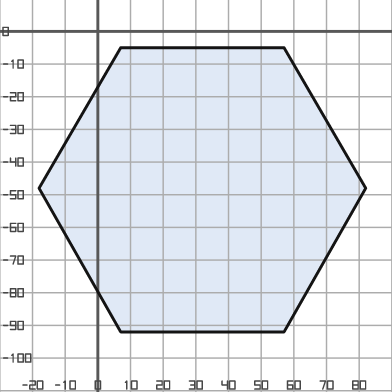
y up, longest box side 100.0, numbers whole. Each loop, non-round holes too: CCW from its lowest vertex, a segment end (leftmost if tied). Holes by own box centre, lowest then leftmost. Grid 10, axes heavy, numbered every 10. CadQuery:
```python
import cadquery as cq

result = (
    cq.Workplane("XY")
    .moveTo(7.0, -92.0)
    .lineTo(57.0, -92.0)
    .lineTo(82.0, -48.0)
    .lineTo(57.0, -5.0)
    .lineTo(7.0, -5.0)
    .lineTo(-18.0, -48.0)
    .close()
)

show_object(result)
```